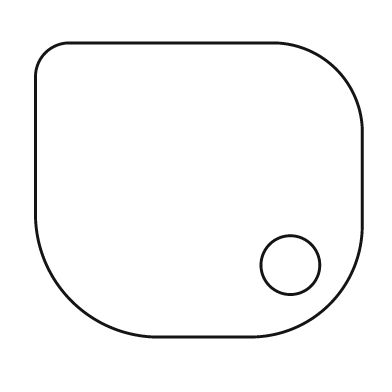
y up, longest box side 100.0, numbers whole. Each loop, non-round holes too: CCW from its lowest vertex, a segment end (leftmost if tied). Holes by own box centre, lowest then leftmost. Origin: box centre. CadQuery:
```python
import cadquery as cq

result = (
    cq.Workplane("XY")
    .moveTo(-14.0, -45.0)
    .lineTo(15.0, -45.0)
    .threePointArc((40.0, -35.0), (50.0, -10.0))
    .lineTo(50.0, 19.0)
    .threePointArc((42.0, 37.0), (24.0, 45.0))
    .lineTo(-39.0, 45.0)
    .threePointArc((-47.0, 42.0), (-50.0, 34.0))
    .lineTo(-50.0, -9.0)
    .threePointArc((-39.0, -34.0), (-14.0, -45.0))
    .close()
    .moveTo(28.0, -23.0)
    .circle(9.0)
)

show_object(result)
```